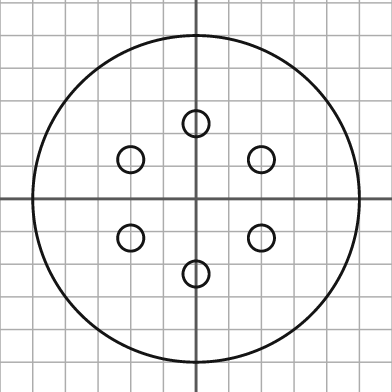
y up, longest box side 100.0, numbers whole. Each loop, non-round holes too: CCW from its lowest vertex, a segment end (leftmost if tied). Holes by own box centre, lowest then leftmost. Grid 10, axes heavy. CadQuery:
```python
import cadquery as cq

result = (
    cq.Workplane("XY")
    .moveTo(0.0, 0.0)
    .circle(50.0)
    .moveTo(0.0, -23.0)
    .circle(4.0)
    .moveTo(-20.0, -12.0)
    .circle(4.0)
    .moveTo(20.0, -12.0)
    .circle(4.0)
    .moveTo(-20.0, 12.0)
    .circle(4.0)
    .moveTo(20.0, 12.0)
    .circle(4.0)
    .moveTo(0.0, 23.0)
    .circle(4.0)
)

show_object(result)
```